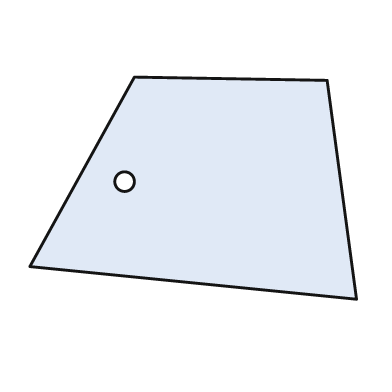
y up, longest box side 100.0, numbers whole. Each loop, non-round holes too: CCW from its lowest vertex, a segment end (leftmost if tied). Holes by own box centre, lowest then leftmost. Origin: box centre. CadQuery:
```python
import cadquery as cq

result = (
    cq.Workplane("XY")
    .moveTo(50.0, -34.0)
    .lineTo(41.0, 33.0)
    .lineTo(-18.0, 34.0)
    .lineTo(-50.0, -24.0)
    .close()
    .moveTo(-21.0, 2.0)
    .circle(3.0)
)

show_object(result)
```